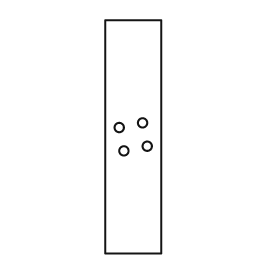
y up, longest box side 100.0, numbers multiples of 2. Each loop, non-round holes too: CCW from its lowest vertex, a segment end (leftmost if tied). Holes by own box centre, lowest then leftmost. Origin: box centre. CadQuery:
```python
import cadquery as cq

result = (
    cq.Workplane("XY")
    .moveTo(-12.0, -50.0)
    .lineTo(12.0, -50.0)
    .lineTo(12.0, 50.0)
    .lineTo(-12.0, 50.0)
    .close()
    .moveTo(-4.0, -6.0)
    .circle(2.0)
    .moveTo(6.0, -4.0)
    .circle(2.0)
    .moveTo(-6.0, 4.0)
    .circle(2.0)
    .moveTo(4.0, 6.0)
    .circle(2.0)
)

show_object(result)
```